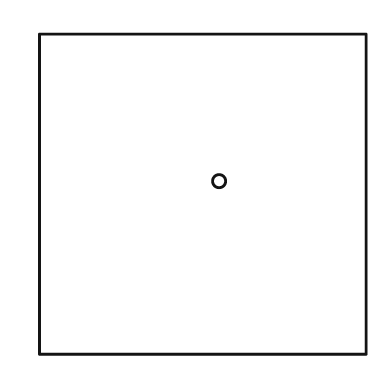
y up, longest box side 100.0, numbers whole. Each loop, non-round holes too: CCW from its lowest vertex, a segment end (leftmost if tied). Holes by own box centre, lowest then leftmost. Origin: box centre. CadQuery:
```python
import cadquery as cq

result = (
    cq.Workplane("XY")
    .moveTo(-50.0, -49.0)
    .lineTo(50.0, -49.0)
    .lineTo(50.0, 49.0)
    .lineTo(-50.0, 49.0)
    .close()
    .moveTo(5.0, 4.0)
    .circle(2.0)
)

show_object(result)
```